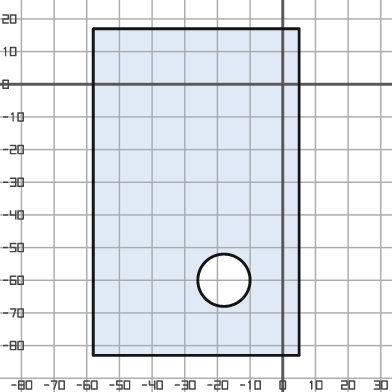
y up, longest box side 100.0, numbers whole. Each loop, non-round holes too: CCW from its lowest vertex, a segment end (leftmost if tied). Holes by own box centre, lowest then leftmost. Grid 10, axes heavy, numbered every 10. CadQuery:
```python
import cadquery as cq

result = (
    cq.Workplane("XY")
    .moveTo(-58.0, -83.0)
    .lineTo(5.0, -83.0)
    .lineTo(5.0, 17.0)
    .lineTo(-58.0, 17.0)
    .close()
    .moveTo(-18.0, -60.0)
    .circle(8.0)
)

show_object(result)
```